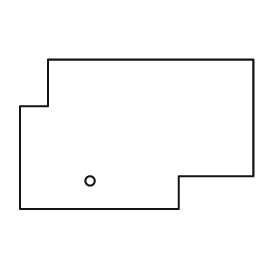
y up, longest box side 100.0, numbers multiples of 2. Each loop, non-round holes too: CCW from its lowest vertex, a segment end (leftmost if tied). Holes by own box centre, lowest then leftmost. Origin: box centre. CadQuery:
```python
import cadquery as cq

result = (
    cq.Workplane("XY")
    .moveTo(-50.0, -32.0)
    .lineTo(18.0, -32.0)
    .lineTo(18.0, -18.0)
    .lineTo(50.0, -18.0)
    .lineTo(50.0, 32.0)
    .lineTo(-38.0, 32.0)
    .lineTo(-38.0, 12.0)
    .lineTo(-50.0, 12.0)
    .close()
    .moveTo(-20.0, -20.0)
    .circle(2.0)
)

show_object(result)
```